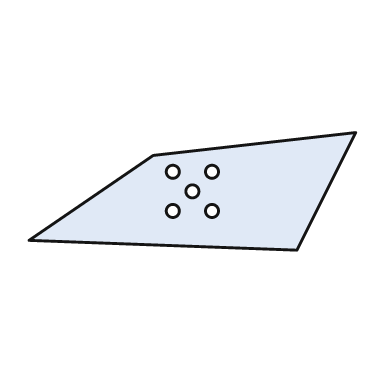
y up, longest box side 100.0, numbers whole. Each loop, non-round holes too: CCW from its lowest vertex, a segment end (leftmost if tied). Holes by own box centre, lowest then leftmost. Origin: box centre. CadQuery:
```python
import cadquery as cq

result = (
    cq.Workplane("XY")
    .moveTo(32.0, -18.0)
    .lineTo(50.0, 18.0)
    .lineTo(-12.0, 11.0)
    .lineTo(-50.0, -15.0)
    .close()
    .moveTo(-6.0, -6.0)
    .circle(2.0)
    .moveTo(6.0, -6.0)
    .circle(2.0)
    .moveTo(0.0, 0.0)
    .circle(2.0)
    .moveTo(-6.0, 6.0)
    .circle(2.0)
    .moveTo(6.0, 6.0)
    .circle(2.0)
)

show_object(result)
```